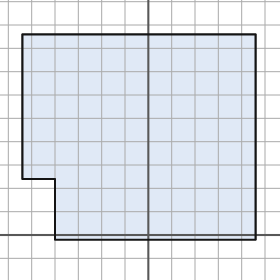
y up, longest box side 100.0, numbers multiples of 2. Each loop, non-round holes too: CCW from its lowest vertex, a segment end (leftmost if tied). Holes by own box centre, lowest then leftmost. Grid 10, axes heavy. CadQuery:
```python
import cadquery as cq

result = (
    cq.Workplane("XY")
    .moveTo(-40.0, -2.0)
    .lineTo(46.0, -2.0)
    .lineTo(46.0, 86.0)
    .lineTo(-54.0, 86.0)
    .lineTo(-54.0, 24.0)
    .lineTo(-40.0, 24.0)
    .close()
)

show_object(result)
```